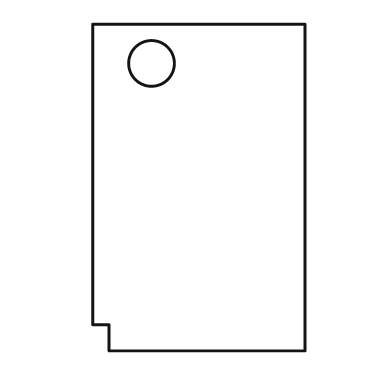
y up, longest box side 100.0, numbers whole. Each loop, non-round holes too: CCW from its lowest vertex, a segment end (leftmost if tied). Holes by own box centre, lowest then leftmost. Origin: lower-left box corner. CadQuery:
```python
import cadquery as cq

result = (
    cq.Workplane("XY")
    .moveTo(5.0, 0.0)
    .lineTo(65.0, 0.0)
    .lineTo(65.0, 100.0)
    .lineTo(0.0, 100.0)
    .lineTo(0.0, 8.0)
    .lineTo(5.0, 8.0)
    .close()
    .moveTo(18.0, 88.0)
    .circle(7.0)
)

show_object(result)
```